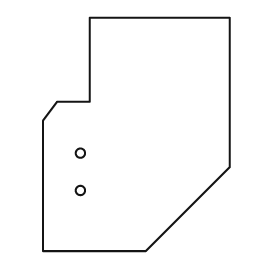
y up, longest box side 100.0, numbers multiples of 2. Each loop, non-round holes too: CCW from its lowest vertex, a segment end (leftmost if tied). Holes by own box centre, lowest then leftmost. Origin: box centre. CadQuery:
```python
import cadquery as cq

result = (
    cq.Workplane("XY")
    .moveTo(-40.0, -50.0)
    .lineTo(4.0, -50.0)
    .lineTo(40.0, -14.0)
    .lineTo(40.0, 50.0)
    .lineTo(-20.0, 50.0)
    .lineTo(-20.0, 14.0)
    .lineTo(-34.0, 14.0)
    .lineTo(-40.0, 6.0)
    .close()
    .moveTo(-24.0, -24.0)
    .circle(2.0)
    .moveTo(-24.0, -8.0)
    .circle(2.0)
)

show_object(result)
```